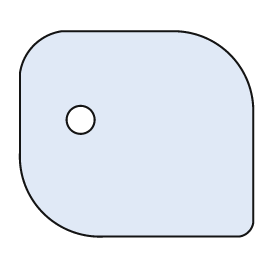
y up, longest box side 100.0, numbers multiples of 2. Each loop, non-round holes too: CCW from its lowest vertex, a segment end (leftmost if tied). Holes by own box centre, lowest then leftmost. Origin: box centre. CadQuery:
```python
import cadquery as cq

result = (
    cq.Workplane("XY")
    .moveTo(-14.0, -44.0)
    .lineTo(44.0, -44.0)
    .threePointArc((48.0, -42.0), (50.0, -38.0))
    .lineTo(50.0, 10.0)
    .threePointArc((40.0, 34.0), (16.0, 44.0))
    .lineTo(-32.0, 44.0)
    .threePointArc((-44.0, 38.0), (-50.0, 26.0))
    .lineTo(-50.0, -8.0)
    .threePointArc((-40.0, -34.0), (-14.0, -44.0))
    .close()
    .moveTo(-24.0, 6.0)
    .circle(6.0)
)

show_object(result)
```